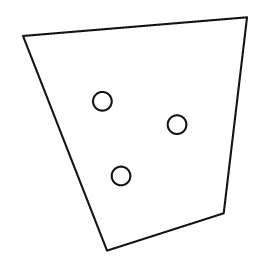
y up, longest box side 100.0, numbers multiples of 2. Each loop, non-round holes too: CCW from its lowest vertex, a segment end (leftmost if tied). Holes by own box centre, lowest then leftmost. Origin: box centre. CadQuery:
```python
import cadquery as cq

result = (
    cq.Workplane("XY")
    .moveTo(-12.0, -50.0)
    .lineTo(38.0, -34.0)
    .lineTo(48.0, 50.0)
    .lineTo(-48.0, 42.0)
    .close()
    .moveTo(-6.0, -18.0)
    .circle(4.0)
    .moveTo(18.0, 4.0)
    .circle(4.0)
    .moveTo(-14.0, 14.0)
    .circle(4.0)
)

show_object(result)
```